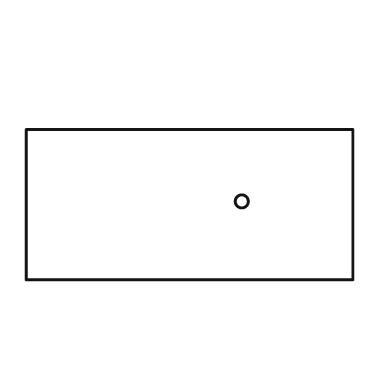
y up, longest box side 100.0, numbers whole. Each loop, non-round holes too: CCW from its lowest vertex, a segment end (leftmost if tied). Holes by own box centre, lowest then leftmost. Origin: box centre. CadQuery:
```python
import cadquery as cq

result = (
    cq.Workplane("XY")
    .moveTo(-50.0, -23.0)
    .lineTo(50.0, -23.0)
    .lineTo(50.0, 23.0)
    .lineTo(-50.0, 23.0)
    .close()
    .moveTo(16.0, 1.0)
    .circle(2.0)
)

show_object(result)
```